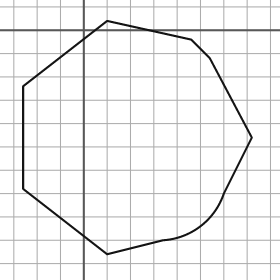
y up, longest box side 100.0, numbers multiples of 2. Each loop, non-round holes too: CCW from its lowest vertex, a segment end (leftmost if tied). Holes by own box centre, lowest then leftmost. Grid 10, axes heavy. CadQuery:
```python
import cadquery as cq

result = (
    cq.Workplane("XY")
    .moveTo(10.0, -96.0)
    .lineTo(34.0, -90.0)
    .threePointArc((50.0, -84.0), (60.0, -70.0))
    .lineTo(72.0, -46.0)
    .lineTo(54.0, -12.0)
    .lineTo(46.0, -4.0)
    .lineTo(10.0, 4.0)
    .lineTo(-26.0, -24.0)
    .lineTo(-26.0, -68.0)
    .close()
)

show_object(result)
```